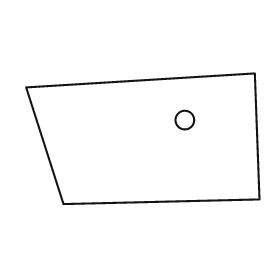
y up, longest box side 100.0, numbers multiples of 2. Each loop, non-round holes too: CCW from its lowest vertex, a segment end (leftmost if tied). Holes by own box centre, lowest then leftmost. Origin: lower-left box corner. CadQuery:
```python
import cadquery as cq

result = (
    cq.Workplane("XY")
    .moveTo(16.0, 0.0)
    .lineTo(100.0, 2.0)
    .lineTo(98.0, 56.0)
    .lineTo(0.0, 50.0)
    .close()
    .moveTo(68.0, 36.0)
    .circle(4.0)
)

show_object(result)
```